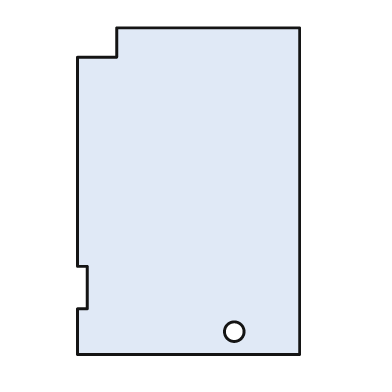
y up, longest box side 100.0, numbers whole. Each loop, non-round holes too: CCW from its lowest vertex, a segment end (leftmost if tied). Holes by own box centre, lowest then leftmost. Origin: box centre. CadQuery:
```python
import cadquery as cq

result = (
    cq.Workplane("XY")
    .moveTo(-34.0, -50.0)
    .lineTo(34.0, -50.0)
    .lineTo(34.0, 50.0)
    .lineTo(-22.0, 50.0)
    .lineTo(-22.0, 41.0)
    .lineTo(-34.0, 41.0)
    .lineTo(-34.0, -23.0)
    .lineTo(-31.0, -23.0)
    .lineTo(-31.0, -36.0)
    .lineTo(-34.0, -36.0)
    .close()
    .moveTo(14.0, -43.0)
    .circle(3.0)
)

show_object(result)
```